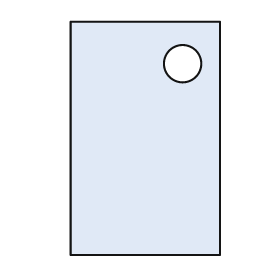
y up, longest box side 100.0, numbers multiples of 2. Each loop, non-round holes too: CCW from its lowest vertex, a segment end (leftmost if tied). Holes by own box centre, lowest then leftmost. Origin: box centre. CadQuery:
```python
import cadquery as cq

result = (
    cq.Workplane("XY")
    .moveTo(-32.0, -50.0)
    .lineTo(32.0, -50.0)
    .lineTo(32.0, 50.0)
    .lineTo(-32.0, 50.0)
    .close()
    .moveTo(16.0, 32.0)
    .circle(8.0)
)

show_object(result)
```